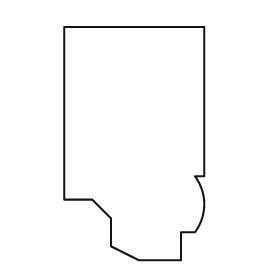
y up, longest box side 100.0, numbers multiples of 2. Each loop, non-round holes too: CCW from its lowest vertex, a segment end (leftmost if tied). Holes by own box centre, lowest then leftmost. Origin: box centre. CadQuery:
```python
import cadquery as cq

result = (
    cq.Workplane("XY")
    .moveTo(2.0, -50.0)
    .lineTo(20.0, -50.0)
    .lineTo(20.0, -38.0)
    .lineTo(26.0, -38.0)
    .threePointArc((30.0, -26.0), (26.0, -14.0))
    .lineTo(30.0, -14.0)
    .lineTo(30.0, 50.0)
    .lineTo(-30.0, 50.0)
    .lineTo(-30.0, -24.0)
    .lineTo(-18.0, -24.0)
    .lineTo(-10.0, -32.0)
    .lineTo(-10.0, -44.0)
    .close()
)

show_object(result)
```